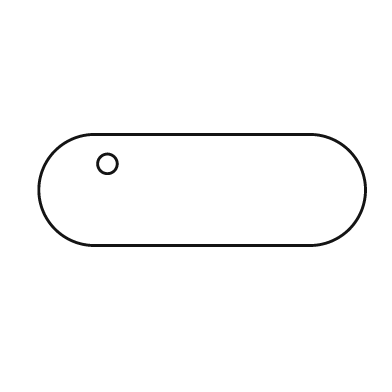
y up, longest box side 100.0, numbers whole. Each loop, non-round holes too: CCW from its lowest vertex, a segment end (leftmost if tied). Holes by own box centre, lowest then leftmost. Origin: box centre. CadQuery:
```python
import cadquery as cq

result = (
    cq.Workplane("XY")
    .moveTo(-33.0, -17.0)
    .lineTo(33.0, -17.0)
    .threePointArc((50.0, 0.0), (33.0, 17.0))
    .lineTo(-33.0, 17.0)
    .threePointArc((-50.0, 0.0), (-33.0, -17.0))
    .close()
    .moveTo(-29.0, 8.0)
    .circle(3.0)
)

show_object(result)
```